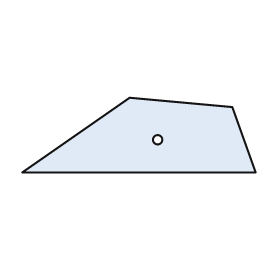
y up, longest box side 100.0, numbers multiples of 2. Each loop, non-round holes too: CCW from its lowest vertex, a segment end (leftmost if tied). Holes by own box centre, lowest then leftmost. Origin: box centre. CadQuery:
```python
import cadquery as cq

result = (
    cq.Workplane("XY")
    .moveTo(-50.0, -16.0)
    .lineTo(50.0, -16.0)
    .lineTo(40.0, 12.0)
    .lineTo(-4.0, 16.0)
    .close()
    .moveTo(8.0, -2.0)
    .circle(2.0)
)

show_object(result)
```